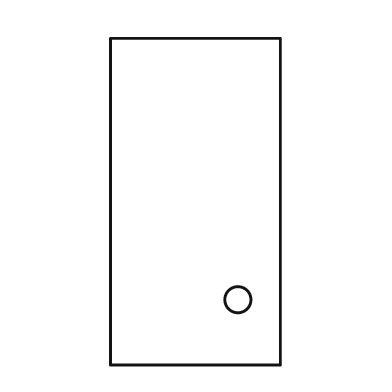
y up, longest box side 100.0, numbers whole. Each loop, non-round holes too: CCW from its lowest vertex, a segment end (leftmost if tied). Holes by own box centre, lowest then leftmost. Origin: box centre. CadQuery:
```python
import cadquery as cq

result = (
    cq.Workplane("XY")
    .moveTo(-26.0, -50.0)
    .lineTo(26.0, -50.0)
    .lineTo(26.0, 50.0)
    .lineTo(-26.0, 50.0)
    .close()
    .moveTo(13.0, -30.0)
    .circle(4.0)
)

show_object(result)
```